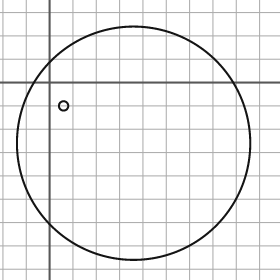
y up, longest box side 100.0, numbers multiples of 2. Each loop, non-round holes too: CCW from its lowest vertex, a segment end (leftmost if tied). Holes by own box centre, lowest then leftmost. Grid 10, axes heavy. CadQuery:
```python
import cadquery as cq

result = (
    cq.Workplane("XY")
    .moveTo(36.0, -26.0)
    .circle(50.0)
    .moveTo(6.0, -10.0)
    .circle(2.0)
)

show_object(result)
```